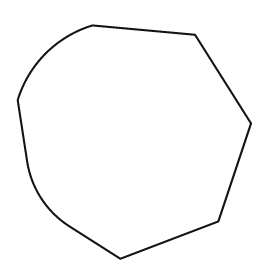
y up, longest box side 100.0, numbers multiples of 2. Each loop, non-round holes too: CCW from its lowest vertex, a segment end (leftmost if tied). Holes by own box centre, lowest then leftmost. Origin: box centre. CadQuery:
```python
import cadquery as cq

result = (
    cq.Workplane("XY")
    .moveTo(-6.0, -50.0)
    .lineTo(36.0, -34.0)
    .lineTo(50.0, 8.0)
    .lineTo(26.0, 46.0)
    .lineTo(-18.0, 50.0)
    .threePointArc((-38.0, 38.0), (-50.0, 18.0))
    .lineTo(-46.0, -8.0)
    .threePointArc((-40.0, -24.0), (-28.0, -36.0))
    .close()
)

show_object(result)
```